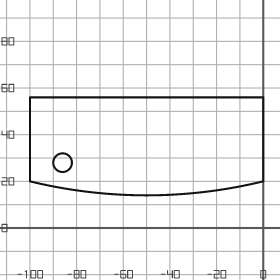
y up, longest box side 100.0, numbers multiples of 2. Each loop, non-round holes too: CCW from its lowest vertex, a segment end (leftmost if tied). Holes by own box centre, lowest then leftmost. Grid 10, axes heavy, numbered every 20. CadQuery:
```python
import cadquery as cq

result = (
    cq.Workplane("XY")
    .moveTo(-100.0, 20.0)
    .threePointArc((-50.0, 14.0), (0.0, 20.0))
    .lineTo(0.0, 56.0)
    .lineTo(-100.0, 56.0)
    .close()
    .moveTo(-86.0, 28.0)
    .circle(4.0)
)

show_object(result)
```